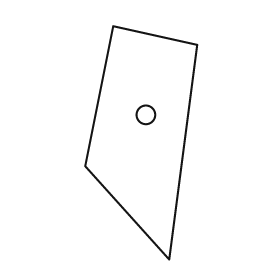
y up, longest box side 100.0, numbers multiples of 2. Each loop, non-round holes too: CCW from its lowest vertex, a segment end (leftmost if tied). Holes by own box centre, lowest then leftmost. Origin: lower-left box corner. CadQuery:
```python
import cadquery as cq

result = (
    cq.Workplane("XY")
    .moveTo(36.0, 0.0)
    .lineTo(48.0, 92.0)
    .lineTo(12.0, 100.0)
    .lineTo(0.0, 40.0)
    .close()
    .moveTo(26.0, 62.0)
    .circle(4.0)
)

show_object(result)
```